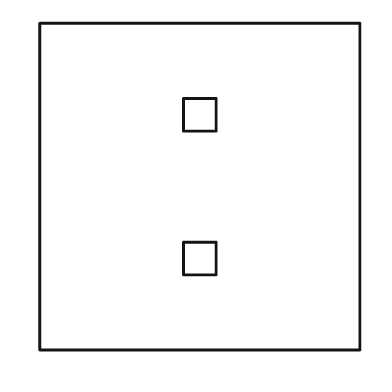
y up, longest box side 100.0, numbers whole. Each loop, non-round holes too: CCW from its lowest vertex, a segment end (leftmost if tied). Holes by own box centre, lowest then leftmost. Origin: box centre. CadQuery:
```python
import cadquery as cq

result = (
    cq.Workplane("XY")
    .moveTo(-49.0, -50.0)
    .lineTo(49.0, -50.0)
    .lineTo(49.0, 50.0)
    .lineTo(-49.0, 50.0)
    .close()
    .moveTo(-5.0, -27.0)
    .lineTo(5.0, -27.0)
    .lineTo(5.0, -17.0)
    .lineTo(-5.0, -17.0)
    .close()
    .moveTo(-5.0, 17.0)
    .lineTo(5.0, 17.0)
    .lineTo(5.0, 27.0)
    .lineTo(-5.0, 27.0)
    .close()
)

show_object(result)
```